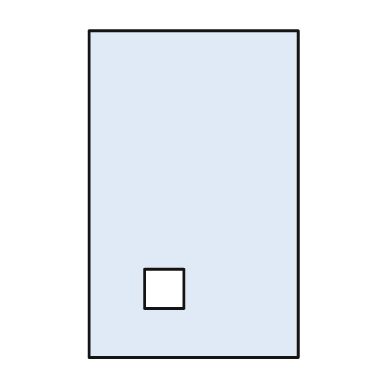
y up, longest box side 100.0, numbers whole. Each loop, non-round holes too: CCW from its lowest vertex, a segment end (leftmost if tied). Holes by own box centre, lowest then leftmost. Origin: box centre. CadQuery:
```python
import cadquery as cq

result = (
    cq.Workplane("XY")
    .moveTo(-32.0, -50.0)
    .lineTo(32.0, -50.0)
    .lineTo(32.0, 50.0)
    .lineTo(-32.0, 50.0)
    .close()
    .moveTo(-15.0, -35.0)
    .lineTo(-3.0, -35.0)
    .lineTo(-3.0, -23.0)
    .lineTo(-15.0, -23.0)
    .close()
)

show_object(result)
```